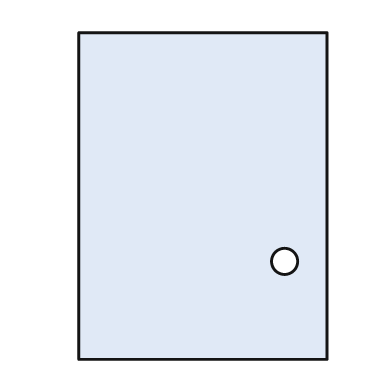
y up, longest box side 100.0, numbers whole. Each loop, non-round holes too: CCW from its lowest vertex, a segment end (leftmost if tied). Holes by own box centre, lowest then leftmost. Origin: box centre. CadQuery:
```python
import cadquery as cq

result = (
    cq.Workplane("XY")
    .moveTo(-38.0, -50.0)
    .lineTo(38.0, -50.0)
    .lineTo(38.0, 50.0)
    .lineTo(-38.0, 50.0)
    .close()
    .moveTo(25.0, -20.0)
    .circle(4.0)
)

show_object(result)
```